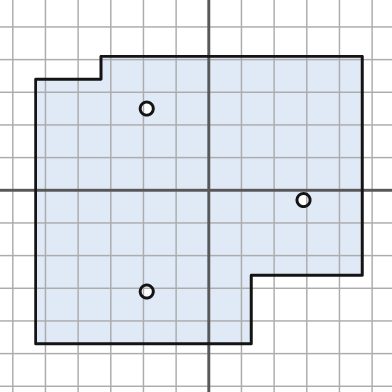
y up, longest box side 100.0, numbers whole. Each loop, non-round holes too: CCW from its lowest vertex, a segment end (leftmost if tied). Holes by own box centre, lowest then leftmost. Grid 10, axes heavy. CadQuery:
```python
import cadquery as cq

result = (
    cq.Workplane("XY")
    .moveTo(-53.0, -47.0)
    .lineTo(13.0, -47.0)
    .lineTo(13.0, -26.0)
    .lineTo(47.0, -26.0)
    .lineTo(47.0, 41.0)
    .lineTo(-33.0, 41.0)
    .lineTo(-33.0, 34.0)
    .lineTo(-53.0, 34.0)
    .close()
    .moveTo(-19.0, -31.0)
    .circle(2.0)
    .moveTo(29.0, -3.0)
    .circle(2.0)
    .moveTo(-19.0, 25.0)
    .circle(2.0)
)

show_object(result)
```